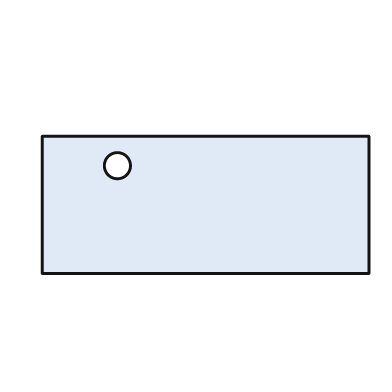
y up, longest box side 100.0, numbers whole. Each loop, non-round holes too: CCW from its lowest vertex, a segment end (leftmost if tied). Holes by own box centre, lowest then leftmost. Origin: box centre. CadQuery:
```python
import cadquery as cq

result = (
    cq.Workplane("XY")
    .moveTo(-50.0, -21.0)
    .lineTo(50.0, -21.0)
    .lineTo(50.0, 21.0)
    .lineTo(-50.0, 21.0)
    .close()
    .moveTo(-27.0, 12.0)
    .circle(4.0)
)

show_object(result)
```